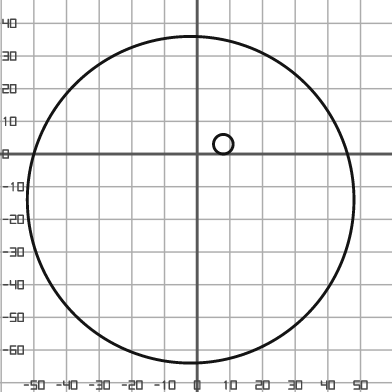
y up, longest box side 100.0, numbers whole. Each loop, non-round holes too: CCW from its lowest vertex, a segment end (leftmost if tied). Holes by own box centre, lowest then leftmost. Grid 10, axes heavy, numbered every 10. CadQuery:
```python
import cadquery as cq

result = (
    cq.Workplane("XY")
    .moveTo(-2.0, -14.0)
    .circle(50.0)
    .moveTo(8.0, 3.0)
    .circle(3.0)
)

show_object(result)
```